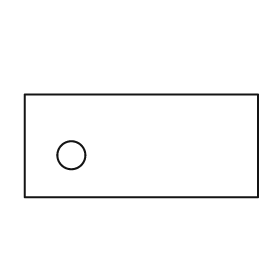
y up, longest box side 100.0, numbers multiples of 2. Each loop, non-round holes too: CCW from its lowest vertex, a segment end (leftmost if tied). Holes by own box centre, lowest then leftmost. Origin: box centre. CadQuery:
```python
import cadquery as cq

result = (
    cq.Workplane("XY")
    .moveTo(-50.0, -22.0)
    .lineTo(50.0, -22.0)
    .lineTo(50.0, 22.0)
    .lineTo(-50.0, 22.0)
    .close()
    .moveTo(-30.0, -4.0)
    .circle(6.0)
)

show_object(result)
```